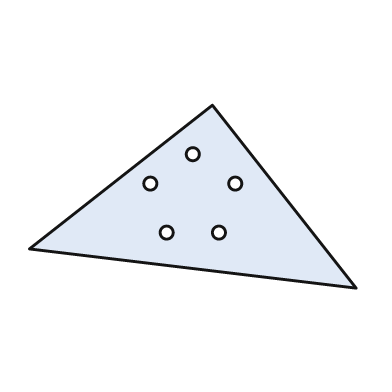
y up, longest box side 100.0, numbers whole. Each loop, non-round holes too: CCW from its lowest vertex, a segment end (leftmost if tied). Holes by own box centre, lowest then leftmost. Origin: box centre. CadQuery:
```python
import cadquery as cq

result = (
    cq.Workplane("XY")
    .moveTo(50.0, -28.0)
    .lineTo(6.0, 28.0)
    .lineTo(-50.0, -16.0)
    .close()
    .moveTo(-8.0, -11.0)
    .circle(2.0)
    .moveTo(8.0, -11.0)
    .circle(2.0)
    .moveTo(-13.0, 4.0)
    .circle(2.0)
    .moveTo(13.0, 4.0)
    .circle(2.0)
    .moveTo(0.0, 13.0)
    .circle(2.0)
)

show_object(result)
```